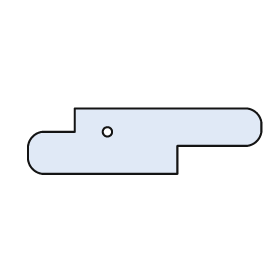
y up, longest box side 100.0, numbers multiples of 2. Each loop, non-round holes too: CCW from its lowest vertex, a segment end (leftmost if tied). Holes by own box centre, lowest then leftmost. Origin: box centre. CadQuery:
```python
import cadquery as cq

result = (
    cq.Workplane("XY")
    .moveTo(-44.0, -14.0)
    .lineTo(14.0, -14.0)
    .lineTo(14.0, -2.0)
    .lineTo(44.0, -2.0)
    .threePointArc((48.0, 0.0), (50.0, 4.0))
    .lineTo(50.0, 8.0)
    .threePointArc((48.0, 12.0), (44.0, 14.0))
    .lineTo(-30.0, 14.0)
    .lineTo(-30.0, 4.0)
    .lineTo(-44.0, 4.0)
    .threePointArc((-48.0, 2.0), (-50.0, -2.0))
    .lineTo(-50.0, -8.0)
    .threePointArc((-48.0, -12.0), (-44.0, -14.0))
    .close()
    .moveTo(-16.0, 4.0)
    .circle(2.0)
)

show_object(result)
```